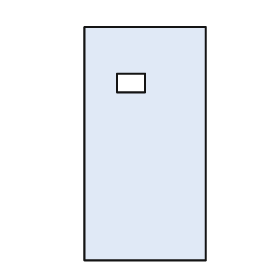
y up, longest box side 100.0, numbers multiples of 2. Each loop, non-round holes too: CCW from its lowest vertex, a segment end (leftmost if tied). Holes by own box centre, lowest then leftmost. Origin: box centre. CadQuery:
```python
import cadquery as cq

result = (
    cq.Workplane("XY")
    .moveTo(-26.0, -50.0)
    .lineTo(26.0, -50.0)
    .lineTo(26.0, 50.0)
    .lineTo(-26.0, 50.0)
    .close()
    .moveTo(-12.0, 22.0)
    .lineTo(0.0, 22.0)
    .lineTo(0.0, 30.0)
    .lineTo(-12.0, 30.0)
    .close()
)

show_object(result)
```